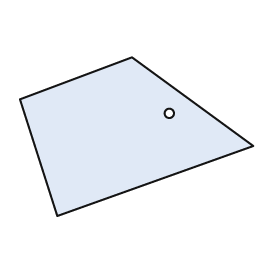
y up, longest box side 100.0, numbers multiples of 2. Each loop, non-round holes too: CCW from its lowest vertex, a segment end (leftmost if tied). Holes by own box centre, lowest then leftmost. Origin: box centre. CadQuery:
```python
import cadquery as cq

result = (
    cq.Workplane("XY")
    .moveTo(-34.0, -34.0)
    .lineTo(50.0, -4.0)
    .lineTo(-2.0, 34.0)
    .lineTo(-50.0, 16.0)
    .close()
    .moveTo(14.0, 10.0)
    .circle(2.0)
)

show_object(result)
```